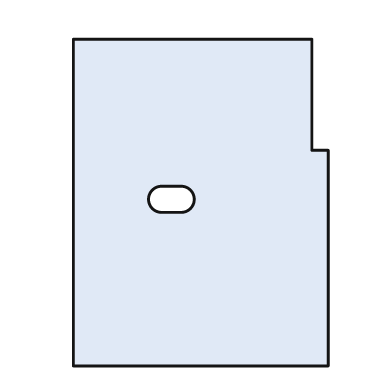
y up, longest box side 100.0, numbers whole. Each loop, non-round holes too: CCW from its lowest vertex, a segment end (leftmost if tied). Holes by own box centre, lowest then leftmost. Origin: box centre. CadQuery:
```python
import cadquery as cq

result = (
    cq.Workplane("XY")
    .moveTo(-39.0, -50.0)
    .lineTo(39.0, -50.0)
    .lineTo(39.0, 16.0)
    .lineTo(34.0, 16.0)
    .lineTo(34.0, 50.0)
    .lineTo(-39.0, 50.0)
    .close()
    .moveTo(-12.0, -3.0)
    .lineTo(-6.0, -3.0)
    .threePointArc((-2.0, 1.0), (-6.0, 5.0))
    .lineTo(-12.0, 5.0)
    .threePointArc((-16.0, 1.0), (-12.0, -3.0))
    .close()
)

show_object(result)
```